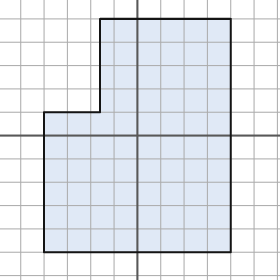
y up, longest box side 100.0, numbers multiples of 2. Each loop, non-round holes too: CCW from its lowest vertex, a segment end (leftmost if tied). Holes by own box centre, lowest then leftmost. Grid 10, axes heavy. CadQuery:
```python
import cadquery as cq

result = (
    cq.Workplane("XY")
    .moveTo(-40.0, -50.0)
    .lineTo(40.0, -50.0)
    .lineTo(40.0, 50.0)
    .lineTo(-16.0, 50.0)
    .lineTo(-16.0, 10.0)
    .lineTo(-40.0, 10.0)
    .close()
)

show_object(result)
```